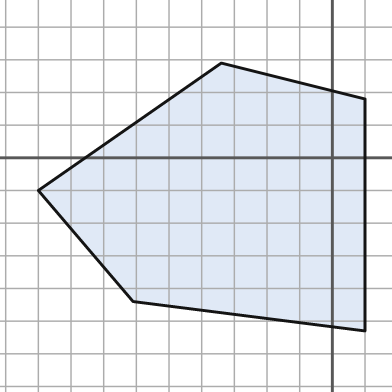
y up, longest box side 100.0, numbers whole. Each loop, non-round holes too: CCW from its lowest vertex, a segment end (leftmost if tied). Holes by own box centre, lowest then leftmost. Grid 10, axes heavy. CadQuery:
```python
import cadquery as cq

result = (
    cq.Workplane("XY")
    .moveTo(10.0, -53.0)
    .lineTo(10.0, 18.0)
    .lineTo(-34.0, 29.0)
    .lineTo(-90.0, -10.0)
    .lineTo(-61.0, -44.0)
    .close()
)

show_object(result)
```